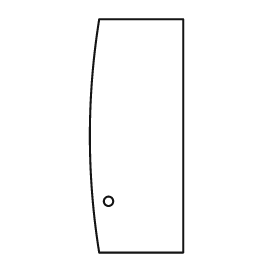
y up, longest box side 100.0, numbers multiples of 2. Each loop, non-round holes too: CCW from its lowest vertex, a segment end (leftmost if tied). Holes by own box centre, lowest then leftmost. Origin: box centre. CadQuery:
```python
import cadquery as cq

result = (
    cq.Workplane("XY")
    .moveTo(-16.0, -50.0)
    .lineTo(20.0, -50.0)
    .lineTo(20.0, 50.0)
    .lineTo(-16.0, 50.0)
    .threePointArc((-20.0, 0.0), (-16.0, -50.0))
    .close()
    .moveTo(-12.0, -28.0)
    .circle(2.0)
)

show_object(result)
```